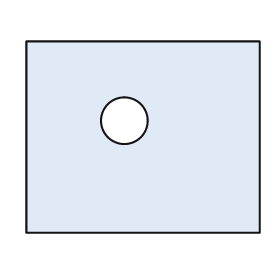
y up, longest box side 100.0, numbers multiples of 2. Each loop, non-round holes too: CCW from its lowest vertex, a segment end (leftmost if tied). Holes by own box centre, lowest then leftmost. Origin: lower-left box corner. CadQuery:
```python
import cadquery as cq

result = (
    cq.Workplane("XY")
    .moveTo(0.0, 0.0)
    .lineTo(100.0, 0.0)
    .lineTo(100.0, 82.0)
    .lineTo(0.0, 82.0)
    .close()
    .moveTo(42.0, 48.0)
    .circle(10.0)
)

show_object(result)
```